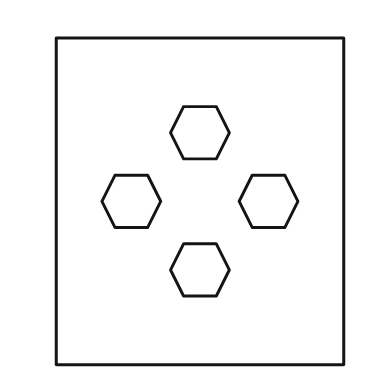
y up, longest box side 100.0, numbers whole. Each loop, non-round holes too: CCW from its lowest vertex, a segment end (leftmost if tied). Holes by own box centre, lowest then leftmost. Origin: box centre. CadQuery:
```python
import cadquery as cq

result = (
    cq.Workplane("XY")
    .moveTo(-44.0, -50.0)
    .lineTo(44.0, -50.0)
    .lineTo(44.0, 50.0)
    .lineTo(-44.0, 50.0)
    .close()
    .moveTo(-5.0, -29.0)
    .lineTo(5.0, -29.0)
    .lineTo(9.0, -21.0)
    .lineTo(5.0, -13.0)
    .lineTo(-5.0, -13.0)
    .lineTo(-9.0, -21.0)
    .close()
    .moveTo(-26.0, -8.0)
    .lineTo(-16.0, -8.0)
    .lineTo(-12.0, 0.0)
    .lineTo(-16.0, 8.0)
    .lineTo(-26.0, 8.0)
    .lineTo(-30.0, 0.0)
    .close()
    .moveTo(16.0, -8.0)
    .lineTo(26.0, -8.0)
    .lineTo(30.0, 0.0)
    .lineTo(26.0, 8.0)
    .lineTo(16.0, 8.0)
    .lineTo(12.0, 0.0)
    .close()
    .moveTo(-5.0, 13.0)
    .lineTo(5.0, 13.0)
    .lineTo(9.0, 21.0)
    .lineTo(5.0, 29.0)
    .lineTo(-5.0, 29.0)
    .lineTo(-9.0, 21.0)
    .close()
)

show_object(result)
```